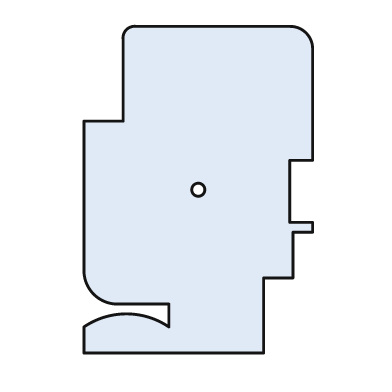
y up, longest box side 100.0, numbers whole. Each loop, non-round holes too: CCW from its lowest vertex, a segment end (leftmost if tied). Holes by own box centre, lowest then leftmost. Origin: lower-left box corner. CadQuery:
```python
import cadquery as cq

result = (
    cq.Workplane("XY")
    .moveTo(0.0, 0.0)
    .lineTo(55.0, 0.0)
    .lineTo(55.0, 23.0)
    .lineTo(64.0, 23.0)
    .lineTo(64.0, 37.0)
    .lineTo(70.0, 37.0)
    .lineTo(70.0, 40.0)
    .lineTo(63.0, 40.0)
    .lineTo(63.0, 59.0)
    .lineTo(70.0, 59.0)
    .lineTo(70.0, 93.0)
    .threePointArc((68.0, 98.0), (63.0, 100.0))
    .lineTo(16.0, 100.0)
    .threePointArc((13.0, 99.0), (12.0, 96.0))
    .lineTo(12.0, 71.0)
    .lineTo(0.0, 71.0)
    .lineTo(0.0, 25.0)
    .threePointArc((3.0, 18.0), (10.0, 15.0))
    .lineTo(26.0, 15.0)
    .lineTo(26.0, 8.0)
    .threePointArc((13.0, 12.0), (0.0, 8.0))
    .close()
    .moveTo(35.0, 50.0)
    .circle(2.0)
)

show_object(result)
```